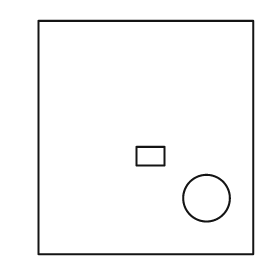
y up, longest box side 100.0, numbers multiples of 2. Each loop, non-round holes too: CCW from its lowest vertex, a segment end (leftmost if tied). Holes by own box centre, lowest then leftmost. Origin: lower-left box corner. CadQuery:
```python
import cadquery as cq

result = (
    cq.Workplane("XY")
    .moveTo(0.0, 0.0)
    .lineTo(92.0, 0.0)
    .lineTo(92.0, 100.0)
    .lineTo(0.0, 100.0)
    .close()
    .moveTo(72.0, 24.0)
    .circle(10.0)
    .moveTo(42.0, 38.0)
    .lineTo(54.0, 38.0)
    .lineTo(54.0, 46.0)
    .lineTo(42.0, 46.0)
    .close()
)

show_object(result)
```